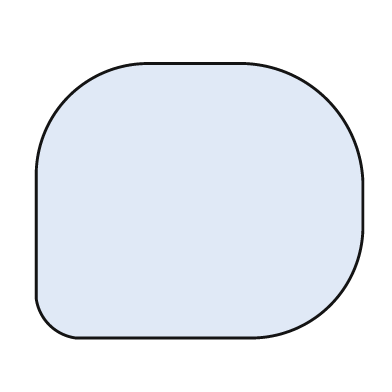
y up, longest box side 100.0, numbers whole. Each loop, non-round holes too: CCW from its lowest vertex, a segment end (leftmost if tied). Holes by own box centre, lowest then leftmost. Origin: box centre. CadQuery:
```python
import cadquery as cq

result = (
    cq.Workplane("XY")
    .moveTo(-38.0, -42.0)
    .lineTo(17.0, -42.0)
    .threePointArc((40.0, -32.0), (50.0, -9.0))
    .lineTo(50.0, 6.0)
    .threePointArc((39.0, 31.0), (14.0, 42.0))
    .lineTo(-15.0, 42.0)
    .threePointArc((-40.0, 32.0), (-50.0, 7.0))
    .lineTo(-50.0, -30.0)
    .threePointArc((-46.0, -38.0), (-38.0, -42.0))
    .close()
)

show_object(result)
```